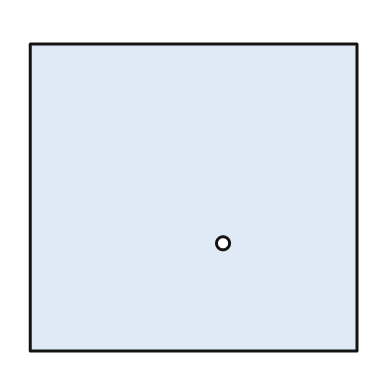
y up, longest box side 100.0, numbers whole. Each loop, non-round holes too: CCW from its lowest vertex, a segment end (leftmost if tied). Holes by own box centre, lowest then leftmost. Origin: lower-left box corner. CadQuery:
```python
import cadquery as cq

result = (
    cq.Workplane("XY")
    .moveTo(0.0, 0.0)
    .lineTo(100.0, 0.0)
    .lineTo(100.0, 94.0)
    .lineTo(0.0, 94.0)
    .close()
    .moveTo(59.0, 33.0)
    .circle(2.0)
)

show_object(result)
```